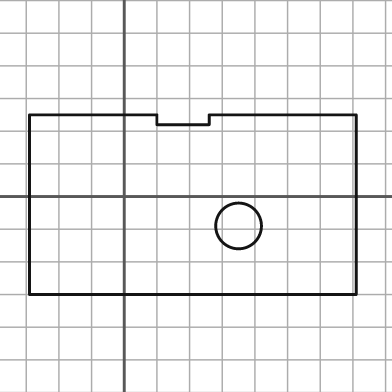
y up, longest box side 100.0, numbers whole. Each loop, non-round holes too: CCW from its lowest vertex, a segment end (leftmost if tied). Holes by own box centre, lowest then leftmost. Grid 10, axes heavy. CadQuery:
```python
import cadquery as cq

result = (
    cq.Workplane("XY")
    .moveTo(-29.0, -30.0)
    .lineTo(71.0, -30.0)
    .lineTo(71.0, 25.0)
    .lineTo(26.0, 25.0)
    .lineTo(26.0, 22.0)
    .lineTo(10.0, 22.0)
    .lineTo(10.0, 25.0)
    .lineTo(-29.0, 25.0)
    .close()
    .moveTo(35.0, -9.0)
    .circle(7.0)
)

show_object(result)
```